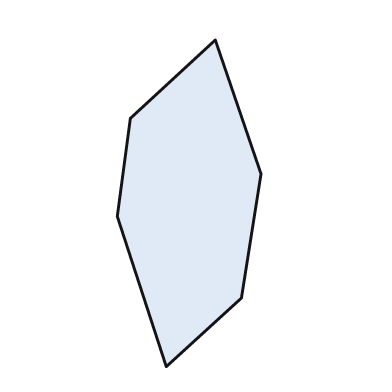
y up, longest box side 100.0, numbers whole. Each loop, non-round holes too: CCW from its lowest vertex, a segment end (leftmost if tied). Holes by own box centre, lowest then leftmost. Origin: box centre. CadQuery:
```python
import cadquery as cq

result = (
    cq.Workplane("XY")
    .moveTo(-7.0, -50.0)
    .lineTo(16.0, -29.0)
    .lineTo(22.0, 9.0)
    .lineTo(8.0, 50.0)
    .lineTo(-18.0, 26.0)
    .lineTo(-22.0, -4.0)
    .close()
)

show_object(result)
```